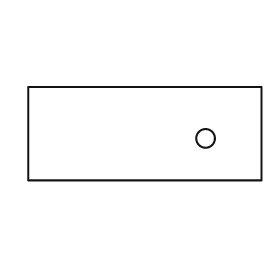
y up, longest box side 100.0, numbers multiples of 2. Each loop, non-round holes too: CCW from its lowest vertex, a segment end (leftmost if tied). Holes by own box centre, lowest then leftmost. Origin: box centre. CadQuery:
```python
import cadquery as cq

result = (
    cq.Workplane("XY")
    .moveTo(-50.0, -20.0)
    .lineTo(50.0, -20.0)
    .lineTo(50.0, 20.0)
    .lineTo(-50.0, 20.0)
    .close()
    .moveTo(26.0, -2.0)
    .circle(4.0)
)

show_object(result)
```